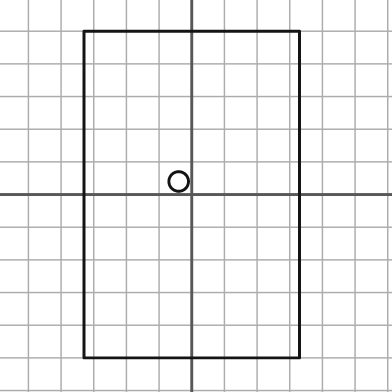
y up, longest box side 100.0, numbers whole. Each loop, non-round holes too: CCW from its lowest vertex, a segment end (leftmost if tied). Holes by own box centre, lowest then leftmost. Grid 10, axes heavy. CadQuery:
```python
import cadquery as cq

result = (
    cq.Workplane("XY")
    .moveTo(-33.0, -50.0)
    .lineTo(33.0, -50.0)
    .lineTo(33.0, 50.0)
    .lineTo(-33.0, 50.0)
    .close()
    .moveTo(-4.0, 4.0)
    .circle(3.0)
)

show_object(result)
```